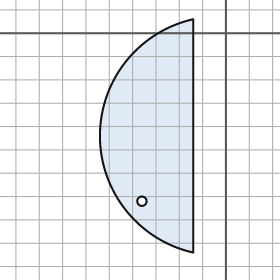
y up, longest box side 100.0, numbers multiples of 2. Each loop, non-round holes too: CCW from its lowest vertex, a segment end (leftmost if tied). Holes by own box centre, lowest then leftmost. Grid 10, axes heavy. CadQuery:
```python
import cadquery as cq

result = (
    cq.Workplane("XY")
    .moveTo(-14.0, -94.0)
    .lineTo(-14.0, 6.0)
    .threePointArc((-54.0, -44.0), (-14.0, -94.0))
    .close()
    .moveTo(-36.0, -72.0)
    .circle(2.0)
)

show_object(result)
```